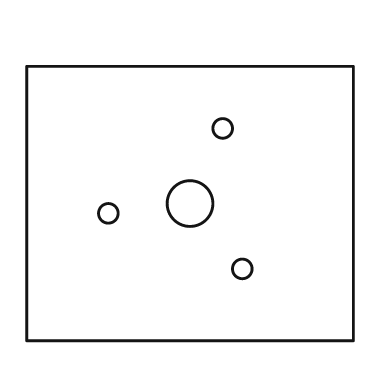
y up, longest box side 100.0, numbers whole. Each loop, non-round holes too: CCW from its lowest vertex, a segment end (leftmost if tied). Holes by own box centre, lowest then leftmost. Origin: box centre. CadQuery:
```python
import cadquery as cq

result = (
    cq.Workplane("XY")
    .moveTo(-50.0, -42.0)
    .lineTo(50.0, -42.0)
    .lineTo(50.0, 42.0)
    .lineTo(-50.0, 42.0)
    .close()
    .moveTo(16.0, -20.0)
    .circle(3.0)
    .moveTo(-25.0, -3.0)
    .circle(3.0)
    .moveTo(0.0, 0.0)
    .circle(7.0)
    .moveTo(10.0, 23.0)
    .circle(3.0)
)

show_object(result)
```